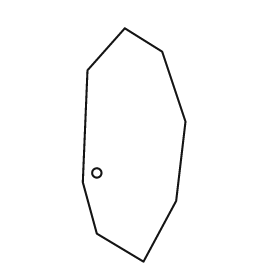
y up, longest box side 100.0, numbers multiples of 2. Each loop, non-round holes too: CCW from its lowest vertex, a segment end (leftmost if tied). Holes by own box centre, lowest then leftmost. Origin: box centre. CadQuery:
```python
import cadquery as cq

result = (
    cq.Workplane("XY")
    .moveTo(4.0, -50.0)
    .lineTo(18.0, -24.0)
    .lineTo(22.0, 10.0)
    .lineTo(12.0, 40.0)
    .lineTo(-4.0, 50.0)
    .lineTo(-20.0, 32.0)
    .lineTo(-22.0, -16.0)
    .lineTo(-16.0, -38.0)
    .close()
    .moveTo(-16.0, -12.0)
    .circle(2.0)
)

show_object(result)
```